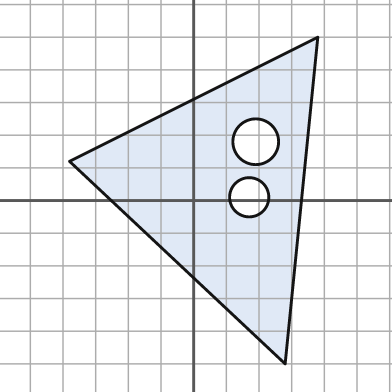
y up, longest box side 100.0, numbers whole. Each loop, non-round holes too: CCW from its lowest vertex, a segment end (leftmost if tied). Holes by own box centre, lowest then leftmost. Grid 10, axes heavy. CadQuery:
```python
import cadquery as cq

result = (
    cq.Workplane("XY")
    .moveTo(28.0, -50.0)
    .lineTo(38.0, 50.0)
    .lineTo(-38.0, 12.0)
    .close()
    .moveTo(17.0, 1.0)
    .circle(6.0)
    .moveTo(19.0, 18.0)
    .circle(7.0)
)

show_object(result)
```